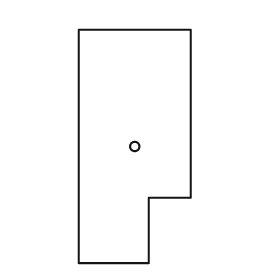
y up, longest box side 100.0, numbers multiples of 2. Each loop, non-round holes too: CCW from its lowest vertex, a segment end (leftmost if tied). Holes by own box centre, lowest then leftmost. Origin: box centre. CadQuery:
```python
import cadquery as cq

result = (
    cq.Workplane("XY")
    .moveTo(-24.0, -50.0)
    .lineTo(6.0, -50.0)
    .lineTo(6.0, -22.0)
    .lineTo(24.0, -22.0)
    .lineTo(24.0, 50.0)
    .lineTo(-24.0, 50.0)
    .close()
    .moveTo(0.0, 0.0)
    .circle(2.0)
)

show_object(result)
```